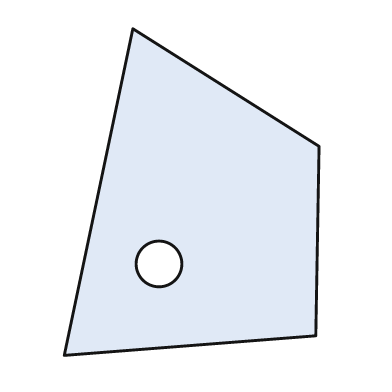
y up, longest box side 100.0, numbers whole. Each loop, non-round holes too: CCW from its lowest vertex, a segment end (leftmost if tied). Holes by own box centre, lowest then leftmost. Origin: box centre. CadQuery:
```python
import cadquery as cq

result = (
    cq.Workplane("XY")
    .moveTo(-39.0, -50.0)
    .lineTo(38.0, -44.0)
    .lineTo(39.0, 14.0)
    .lineTo(-18.0, 50.0)
    .close()
    .moveTo(-10.0, -22.0)
    .circle(7.0)
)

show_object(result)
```